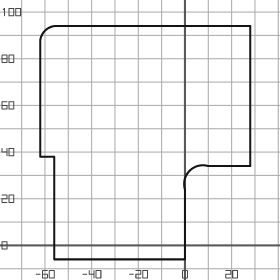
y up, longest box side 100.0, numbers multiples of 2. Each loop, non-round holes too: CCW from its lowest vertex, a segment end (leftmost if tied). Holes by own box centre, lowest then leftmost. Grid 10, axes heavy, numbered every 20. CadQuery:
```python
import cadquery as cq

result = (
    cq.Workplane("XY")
    .moveTo(-56.0, -6.0)
    .lineTo(0.0, -6.0)
    .lineTo(0.0, 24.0)
    .threePointArc((2.0, 32.0), (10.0, 34.0))
    .lineTo(28.0, 34.0)
    .lineTo(28.0, 94.0)
    .lineTo(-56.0, 94.0)
    .threePointArc((-60.0, 92.0), (-62.0, 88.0))
    .lineTo(-62.0, 38.0)
    .lineTo(-56.0, 38.0)
    .close()
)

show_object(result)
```